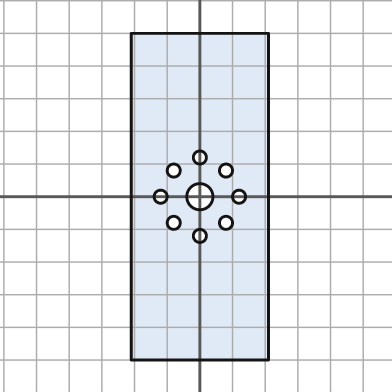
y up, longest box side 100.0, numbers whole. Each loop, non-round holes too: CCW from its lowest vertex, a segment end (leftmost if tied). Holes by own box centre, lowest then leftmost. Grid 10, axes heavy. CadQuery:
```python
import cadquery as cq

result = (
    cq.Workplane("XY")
    .moveTo(-21.0, -50.0)
    .lineTo(21.0, -50.0)
    .lineTo(21.0, 50.0)
    .lineTo(-21.0, 50.0)
    .close()
    .moveTo(0.0, -12.0)
    .circle(2.0)
    .moveTo(-8.0, -8.0)
    .circle(2.0)
    .moveTo(8.0, -8.0)
    .circle(2.0)
    .moveTo(-12.0, 0.0)
    .circle(2.0)
    .moveTo(0.0, 0.0)
    .circle(4.0)
    .moveTo(12.0, 0.0)
    .circle(2.0)
    .moveTo(-8.0, 8.0)
    .circle(2.0)
    .moveTo(8.0, 8.0)
    .circle(2.0)
    .moveTo(0.0, 12.0)
    .circle(2.0)
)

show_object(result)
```